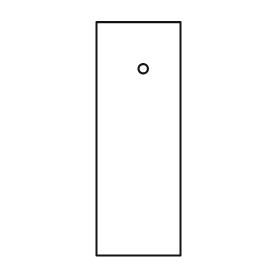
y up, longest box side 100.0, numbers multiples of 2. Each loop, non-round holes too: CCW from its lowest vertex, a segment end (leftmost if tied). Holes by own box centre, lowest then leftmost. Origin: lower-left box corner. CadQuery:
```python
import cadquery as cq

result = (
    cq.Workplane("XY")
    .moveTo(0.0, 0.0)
    .lineTo(36.0, 0.0)
    .lineTo(36.0, 100.0)
    .lineTo(0.0, 100.0)
    .close()
    .moveTo(20.0, 80.0)
    .circle(2.0)
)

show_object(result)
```